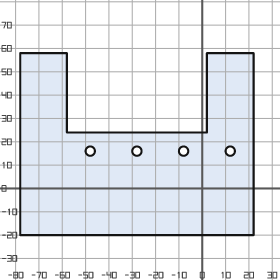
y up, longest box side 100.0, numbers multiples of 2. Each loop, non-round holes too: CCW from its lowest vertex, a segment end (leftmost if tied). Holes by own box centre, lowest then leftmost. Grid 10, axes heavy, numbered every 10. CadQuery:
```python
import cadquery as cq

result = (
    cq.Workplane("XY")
    .moveTo(-78.0, -20.0)
    .lineTo(22.0, -20.0)
    .lineTo(22.0, 58.0)
    .lineTo(2.0, 58.0)
    .lineTo(2.0, 24.0)
    .lineTo(-58.0, 24.0)
    .lineTo(-58.0, 58.0)
    .lineTo(-78.0, 58.0)
    .close()
    .moveTo(-48.0, 16.0)
    .circle(2.0)
    .moveTo(-28.0, 16.0)
    .circle(2.0)
    .moveTo(-8.0, 16.0)
    .circle(2.0)
    .moveTo(12.0, 16.0)
    .circle(2.0)
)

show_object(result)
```